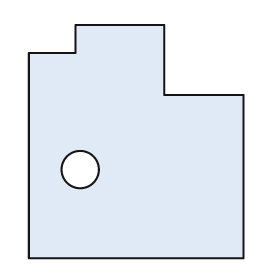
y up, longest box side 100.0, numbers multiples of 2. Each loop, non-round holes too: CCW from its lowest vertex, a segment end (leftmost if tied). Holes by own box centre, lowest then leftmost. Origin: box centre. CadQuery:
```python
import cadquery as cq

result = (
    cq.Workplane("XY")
    .moveTo(-46.0, -50.0)
    .lineTo(46.0, -50.0)
    .lineTo(46.0, 20.0)
    .lineTo(12.0, 20.0)
    .lineTo(12.0, 50.0)
    .lineTo(-26.0, 50.0)
    .lineTo(-26.0, 38.0)
    .lineTo(-46.0, 38.0)
    .close()
    .moveTo(-24.0, -12.0)
    .circle(8.0)
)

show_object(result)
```